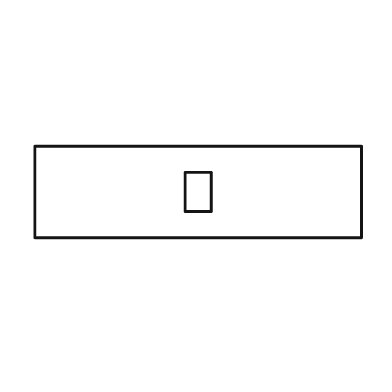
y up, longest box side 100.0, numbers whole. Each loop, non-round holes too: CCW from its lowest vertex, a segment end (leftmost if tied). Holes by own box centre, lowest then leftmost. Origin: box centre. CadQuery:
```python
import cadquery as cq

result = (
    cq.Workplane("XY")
    .moveTo(-50.0, -14.0)
    .lineTo(50.0, -14.0)
    .lineTo(50.0, 14.0)
    .lineTo(-50.0, 14.0)
    .close()
    .moveTo(-4.0, -6.0)
    .lineTo(4.0, -6.0)
    .lineTo(4.0, 6.0)
    .lineTo(-4.0, 6.0)
    .close()
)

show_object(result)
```